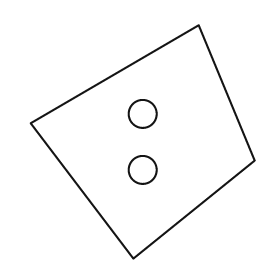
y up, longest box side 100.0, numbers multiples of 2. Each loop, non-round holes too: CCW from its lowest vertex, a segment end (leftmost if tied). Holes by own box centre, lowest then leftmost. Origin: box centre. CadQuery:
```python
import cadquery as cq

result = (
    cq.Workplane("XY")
    .moveTo(-4.0, -50.0)
    .lineTo(48.0, -8.0)
    .lineTo(24.0, 50.0)
    .lineTo(-48.0, 8.0)
    .close()
    .moveTo(0.0, -12.0)
    .circle(6.0)
    .moveTo(0.0, 12.0)
    .circle(6.0)
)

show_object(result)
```